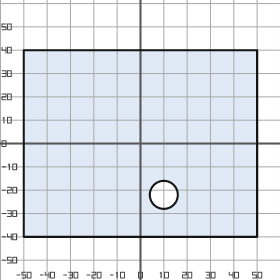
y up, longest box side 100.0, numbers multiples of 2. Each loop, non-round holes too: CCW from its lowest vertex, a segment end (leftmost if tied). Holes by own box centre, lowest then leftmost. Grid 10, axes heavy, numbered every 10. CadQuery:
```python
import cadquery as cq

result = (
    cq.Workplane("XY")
    .moveTo(-50.0, -40.0)
    .lineTo(50.0, -40.0)
    .lineTo(50.0, 40.0)
    .lineTo(-50.0, 40.0)
    .close()
    .moveTo(10.0, -22.0)
    .circle(6.0)
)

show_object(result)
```